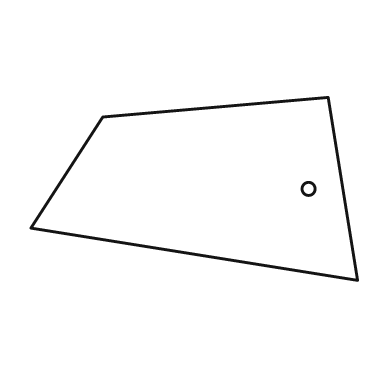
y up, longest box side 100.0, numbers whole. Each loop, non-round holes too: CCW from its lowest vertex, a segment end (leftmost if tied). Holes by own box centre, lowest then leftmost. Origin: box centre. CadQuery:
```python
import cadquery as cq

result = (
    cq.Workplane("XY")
    .moveTo(50.0, -28.0)
    .lineTo(41.0, 28.0)
    .lineTo(-28.0, 22.0)
    .lineTo(-50.0, -12.0)
    .close()
    .moveTo(35.0, 0.0)
    .circle(2.0)
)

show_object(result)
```